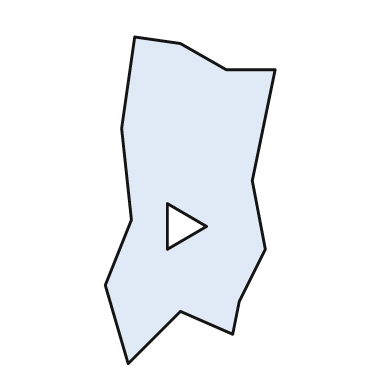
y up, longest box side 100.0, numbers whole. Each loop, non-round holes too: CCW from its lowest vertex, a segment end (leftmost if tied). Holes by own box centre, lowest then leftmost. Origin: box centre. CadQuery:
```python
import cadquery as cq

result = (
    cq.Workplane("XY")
    .moveTo(-19.0, -50.0)
    .lineTo(-3.0, -34.0)
    .lineTo(13.0, -41.0)
    .lineTo(15.0, -31.0)
    .lineTo(23.0, -15.0)
    .lineTo(19.0, 6.0)
    .lineTo(26.0, 40.0)
    .lineTo(11.0, 40.0)
    .lineTo(-3.0, 48.0)
    .lineTo(-17.0, 50.0)
    .lineTo(-21.0, 22.0)
    .lineTo(-18.0, -6.0)
    .lineTo(-26.0, -26.0)
    .close()
    .moveTo(-7.0, -15.0)
    .lineTo(5.0, -8.0)
    .lineTo(-7.0, -1.0)
    .close()
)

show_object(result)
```